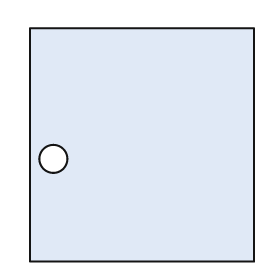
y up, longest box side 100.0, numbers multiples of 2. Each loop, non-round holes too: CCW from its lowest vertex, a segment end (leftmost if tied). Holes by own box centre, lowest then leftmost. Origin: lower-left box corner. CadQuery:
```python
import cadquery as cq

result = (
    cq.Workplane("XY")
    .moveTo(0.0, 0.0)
    .lineTo(96.0, 0.0)
    .lineTo(96.0, 100.0)
    .lineTo(0.0, 100.0)
    .close()
    .moveTo(10.0, 44.0)
    .circle(6.0)
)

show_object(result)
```